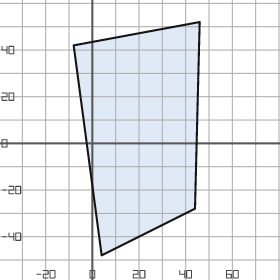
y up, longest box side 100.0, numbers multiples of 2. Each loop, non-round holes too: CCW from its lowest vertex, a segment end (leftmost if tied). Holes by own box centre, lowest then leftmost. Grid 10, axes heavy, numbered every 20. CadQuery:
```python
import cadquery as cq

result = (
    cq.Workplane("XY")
    .moveTo(4.0, -48.0)
    .lineTo(44.0, -28.0)
    .lineTo(46.0, 52.0)
    .lineTo(-8.0, 42.0)
    .close()
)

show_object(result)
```